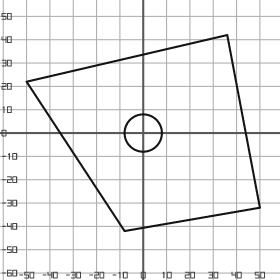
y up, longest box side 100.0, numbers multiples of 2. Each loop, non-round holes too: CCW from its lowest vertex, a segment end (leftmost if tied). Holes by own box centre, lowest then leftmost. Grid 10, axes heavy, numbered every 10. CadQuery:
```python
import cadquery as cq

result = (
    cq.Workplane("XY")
    .moveTo(-8.0, -42.0)
    .lineTo(50.0, -32.0)
    .lineTo(36.0, 42.0)
    .lineTo(-50.0, 22.0)
    .close()
    .moveTo(0.0, 0.0)
    .circle(8.0)
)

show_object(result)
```